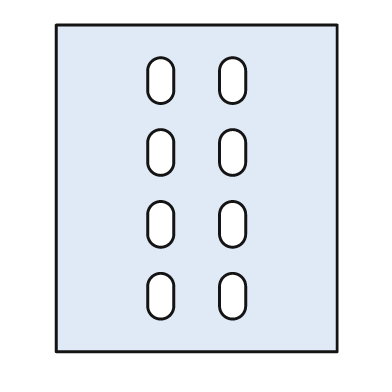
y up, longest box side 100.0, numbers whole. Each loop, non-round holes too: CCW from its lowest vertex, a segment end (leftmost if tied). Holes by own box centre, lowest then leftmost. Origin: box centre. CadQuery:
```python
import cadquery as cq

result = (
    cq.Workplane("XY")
    .moveTo(-43.0, -50.0)
    .lineTo(43.0, -50.0)
    .lineTo(43.0, 50.0)
    .lineTo(-43.0, 50.0)
    .close()
    .moveTo(-15.0, -36.0)
    .threePointArc((-11.0, -40.0), (-7.0, -36.0))
    .lineTo(-7.0, -30.0)
    .threePointArc((-11.0, -26.0), (-15.0, -30.0))
    .close()
    .moveTo(7.0, -36.0)
    .threePointArc((11.0, -40.0), (15.0, -36.0))
    .lineTo(15.0, -30.0)
    .threePointArc((11.0, -26.0), (7.0, -30.0))
    .close()
    .moveTo(-15.0, -14.0)
    .threePointArc((-11.0, -18.0), (-7.0, -14.0))
    .lineTo(-7.0, -8.0)
    .threePointArc((-11.0, -4.0), (-15.0, -8.0))
    .close()
    .moveTo(7.0, -14.0)
    .threePointArc((11.0, -18.0), (15.0, -14.0))
    .lineTo(15.0, -8.0)
    .threePointArc((11.0, -4.0), (7.0, -8.0))
    .close()
    .moveTo(-15.0, 8.0)
    .threePointArc((-11.0, 4.0), (-7.0, 8.0))
    .lineTo(-7.0, 14.0)
    .threePointArc((-11.0, 18.0), (-15.0, 14.0))
    .close()
    .moveTo(7.0, 8.0)
    .threePointArc((11.0, 4.0), (15.0, 8.0))
    .lineTo(15.0, 14.0)
    .threePointArc((11.0, 18.0), (7.0, 14.0))
    .close()
    .moveTo(-15.0, 30.0)
    .threePointArc((-11.0, 26.0), (-7.0, 30.0))
    .lineTo(-7.0, 36.0)
    .threePointArc((-11.0, 40.0), (-15.0, 36.0))
    .close()
    .moveTo(7.0, 30.0)
    .threePointArc((11.0, 26.0), (15.0, 30.0))
    .lineTo(15.0, 36.0)
    .threePointArc((11.0, 40.0), (7.0, 36.0))
    .close()
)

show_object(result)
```